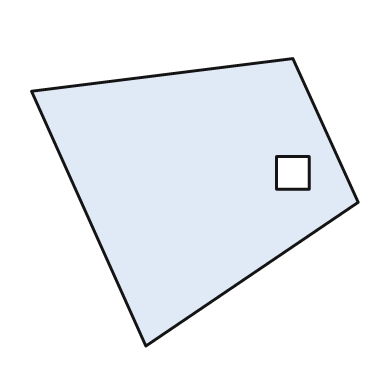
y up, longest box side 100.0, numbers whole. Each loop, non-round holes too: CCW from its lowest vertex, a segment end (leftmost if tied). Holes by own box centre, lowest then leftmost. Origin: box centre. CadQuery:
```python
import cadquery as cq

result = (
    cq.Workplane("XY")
    .moveTo(-15.0, -44.0)
    .lineTo(50.0, 0.0)
    .lineTo(30.0, 44.0)
    .lineTo(-50.0, 34.0)
    .close()
    .moveTo(25.0, 4.0)
    .lineTo(35.0, 4.0)
    .lineTo(35.0, 14.0)
    .lineTo(25.0, 14.0)
    .close()
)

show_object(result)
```